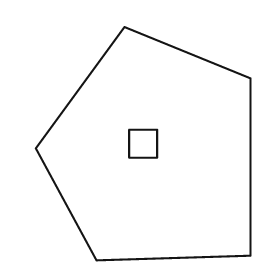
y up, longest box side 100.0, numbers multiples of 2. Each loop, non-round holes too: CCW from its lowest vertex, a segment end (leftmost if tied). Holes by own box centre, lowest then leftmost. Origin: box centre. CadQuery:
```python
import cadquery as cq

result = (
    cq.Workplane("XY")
    .moveTo(-20.0, -50.0)
    .lineTo(46.0, -48.0)
    .lineTo(46.0, 28.0)
    .lineTo(-8.0, 50.0)
    .lineTo(-46.0, -2.0)
    .close()
    .moveTo(-6.0, -6.0)
    .lineTo(6.0, -6.0)
    .lineTo(6.0, 6.0)
    .lineTo(-6.0, 6.0)
    .close()
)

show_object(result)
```